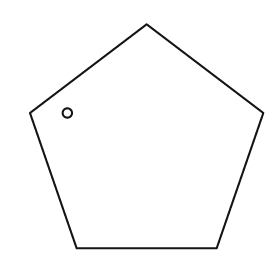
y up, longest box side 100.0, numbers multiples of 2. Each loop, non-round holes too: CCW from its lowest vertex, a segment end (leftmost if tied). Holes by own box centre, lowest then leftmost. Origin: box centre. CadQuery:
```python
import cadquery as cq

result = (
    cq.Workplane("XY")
    .moveTo(-30.0, -48.0)
    .lineTo(30.0, -48.0)
    .lineTo(50.0, 10.0)
    .lineTo(0.0, 48.0)
    .lineTo(-50.0, 10.0)
    .close()
    .moveTo(-34.0, 10.0)
    .circle(2.0)
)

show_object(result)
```